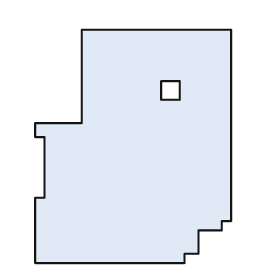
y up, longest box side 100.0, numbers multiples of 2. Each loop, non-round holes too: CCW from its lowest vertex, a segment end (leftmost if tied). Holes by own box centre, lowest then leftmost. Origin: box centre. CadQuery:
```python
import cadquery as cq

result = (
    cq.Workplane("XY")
    .moveTo(-42.0, -50.0)
    .lineTo(22.0, -50.0)
    .lineTo(22.0, -46.0)
    .lineTo(28.0, -46.0)
    .lineTo(28.0, -36.0)
    .lineTo(38.0, -36.0)
    .lineTo(38.0, -32.0)
    .lineTo(42.0, -32.0)
    .lineTo(42.0, 50.0)
    .lineTo(-22.0, 50.0)
    .lineTo(-22.0, 10.0)
    .lineTo(-42.0, 10.0)
    .lineTo(-42.0, 4.0)
    .lineTo(-38.0, 4.0)
    .lineTo(-38.0, -22.0)
    .lineTo(-42.0, -22.0)
    .close()
    .moveTo(12.0, 20.0)
    .lineTo(20.0, 20.0)
    .lineTo(20.0, 28.0)
    .lineTo(12.0, 28.0)
    .close()
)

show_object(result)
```